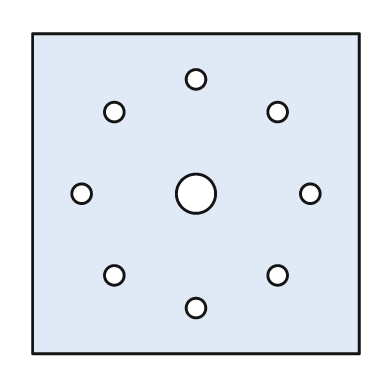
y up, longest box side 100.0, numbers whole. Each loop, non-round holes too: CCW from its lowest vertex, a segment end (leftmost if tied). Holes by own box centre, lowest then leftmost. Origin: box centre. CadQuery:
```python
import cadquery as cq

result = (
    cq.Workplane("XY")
    .moveTo(-50.0, -49.0)
    .lineTo(50.0, -49.0)
    .lineTo(50.0, 49.0)
    .lineTo(-50.0, 49.0)
    .close()
    .moveTo(0.0, -35.0)
    .circle(3.0)
    .moveTo(-25.0, -25.0)
    .circle(3.0)
    .moveTo(25.0, -25.0)
    .circle(3.0)
    .moveTo(-35.0, 0.0)
    .circle(3.0)
    .moveTo(0.0, 0.0)
    .circle(6.0)
    .moveTo(35.0, 0.0)
    .circle(3.0)
    .moveTo(-25.0, 25.0)
    .circle(3.0)
    .moveTo(25.0, 25.0)
    .circle(3.0)
    .moveTo(0.0, 35.0)
    .circle(3.0)
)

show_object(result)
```